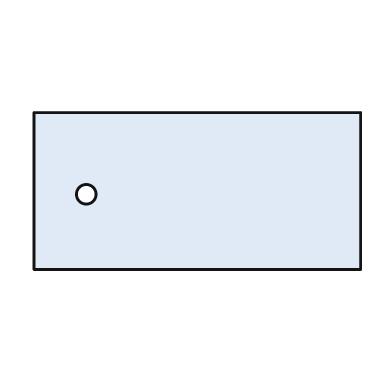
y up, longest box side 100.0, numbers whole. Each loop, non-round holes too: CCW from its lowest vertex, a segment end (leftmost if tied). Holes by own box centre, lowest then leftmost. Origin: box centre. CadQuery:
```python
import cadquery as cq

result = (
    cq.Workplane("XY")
    .moveTo(-50.0, -24.0)
    .lineTo(50.0, -24.0)
    .lineTo(50.0, 24.0)
    .lineTo(-50.0, 24.0)
    .close()
    .moveTo(-34.0, -1.0)
    .circle(3.0)
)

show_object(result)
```